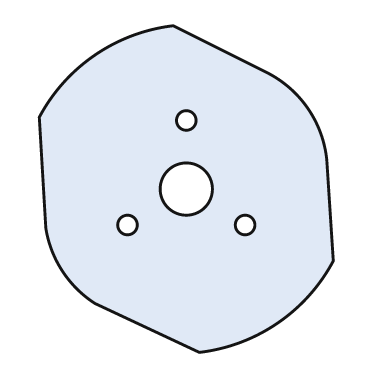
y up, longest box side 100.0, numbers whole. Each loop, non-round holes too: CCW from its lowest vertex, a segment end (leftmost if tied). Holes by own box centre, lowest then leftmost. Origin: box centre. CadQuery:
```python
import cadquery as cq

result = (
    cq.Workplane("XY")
    .moveTo(4.0, -50.0)
    .threePointArc((28.0, -41.0), (45.0, -22.0))
    .lineTo(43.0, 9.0)
    .threePointArc((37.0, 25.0), (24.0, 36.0))
    .lineTo(-4.0, 50.0)
    .threePointArc((-28.0, 41.0), (-45.0, 22.0))
    .lineTo(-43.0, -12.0)
    .threePointArc((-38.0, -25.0), (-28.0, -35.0))
    .close()
    .moveTo(-18.0, -11.0)
    .circle(3.0)
    .moveTo(18.0, -11.0)
    .circle(3.0)
    .moveTo(0.0, 0.0)
    .circle(8.0)
    .moveTo(0.0, 21.0)
    .circle(3.0)
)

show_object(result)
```